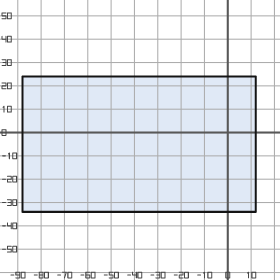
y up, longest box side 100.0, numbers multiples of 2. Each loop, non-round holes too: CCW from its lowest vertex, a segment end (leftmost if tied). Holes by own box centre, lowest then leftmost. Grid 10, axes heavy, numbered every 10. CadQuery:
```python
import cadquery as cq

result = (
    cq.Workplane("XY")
    .moveTo(-88.0, -34.0)
    .lineTo(12.0, -34.0)
    .lineTo(12.0, 24.0)
    .lineTo(-88.0, 24.0)
    .close()
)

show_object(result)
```